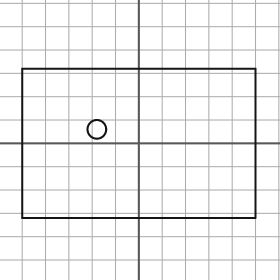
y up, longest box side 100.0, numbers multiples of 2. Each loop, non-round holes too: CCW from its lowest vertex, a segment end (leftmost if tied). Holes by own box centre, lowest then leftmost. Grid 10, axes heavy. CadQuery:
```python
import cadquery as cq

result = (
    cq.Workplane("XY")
    .moveTo(-50.0, -32.0)
    .lineTo(50.0, -32.0)
    .lineTo(50.0, 32.0)
    .lineTo(-50.0, 32.0)
    .close()
    .moveTo(-18.0, 6.0)
    .circle(4.0)
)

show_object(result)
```